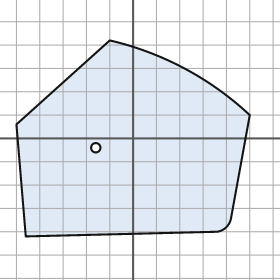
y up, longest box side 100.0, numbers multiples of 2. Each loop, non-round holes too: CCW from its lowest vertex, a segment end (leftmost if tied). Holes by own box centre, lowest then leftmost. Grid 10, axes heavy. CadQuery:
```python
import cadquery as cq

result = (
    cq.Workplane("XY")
    .moveTo(-46.0, -42.0)
    .lineTo(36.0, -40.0)
    .threePointArc((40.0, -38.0), (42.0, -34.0))
    .lineTo(50.0, 10.0)
    .threePointArc((22.0, 30.0), (-10.0, 42.0))
    .lineTo(-50.0, 6.0)
    .close()
    .moveTo(-16.0, -4.0)
    .circle(2.0)
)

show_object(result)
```